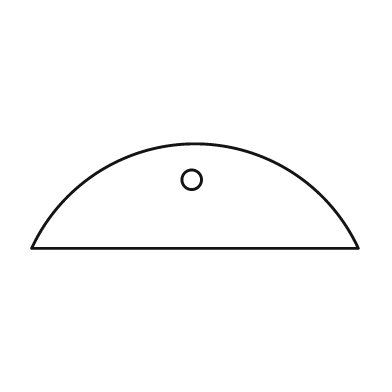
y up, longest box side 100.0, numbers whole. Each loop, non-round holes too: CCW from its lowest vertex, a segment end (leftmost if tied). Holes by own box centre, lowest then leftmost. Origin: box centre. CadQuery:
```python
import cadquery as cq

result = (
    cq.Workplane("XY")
    .moveTo(-50.0, -16.0)
    .lineTo(50.0, -16.0)
    .threePointArc((0.0, 16.0), (-50.0, -16.0))
    .close()
    .moveTo(-1.0, 5.0)
    .circle(3.0)
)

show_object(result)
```